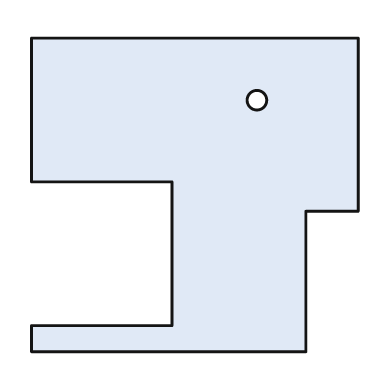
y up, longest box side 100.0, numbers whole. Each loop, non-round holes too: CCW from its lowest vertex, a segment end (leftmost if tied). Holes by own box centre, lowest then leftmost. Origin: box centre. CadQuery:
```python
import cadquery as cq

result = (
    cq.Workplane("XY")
    .moveTo(-50.0, -48.0)
    .lineTo(34.0, -48.0)
    .lineTo(34.0, -5.0)
    .lineTo(50.0, -5.0)
    .lineTo(50.0, 48.0)
    .lineTo(-50.0, 48.0)
    .lineTo(-50.0, 4.0)
    .lineTo(-7.0, 4.0)
    .lineTo(-7.0, -40.0)
    .lineTo(-50.0, -40.0)
    .close()
    .moveTo(19.0, 29.0)
    .circle(3.0)
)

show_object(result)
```